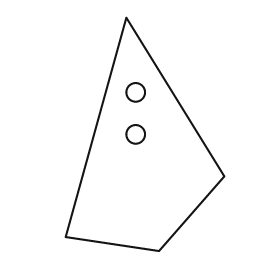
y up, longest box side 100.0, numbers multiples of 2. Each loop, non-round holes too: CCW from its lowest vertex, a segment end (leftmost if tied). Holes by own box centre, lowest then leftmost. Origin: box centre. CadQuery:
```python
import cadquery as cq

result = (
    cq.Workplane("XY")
    .moveTo(6.0, -50.0)
    .lineTo(34.0, -18.0)
    .lineTo(-8.0, 50.0)
    .lineTo(-34.0, -44.0)
    .close()
    .moveTo(-4.0, 0.0)
    .circle(4.0)
    .moveTo(-4.0, 18.0)
    .circle(4.0)
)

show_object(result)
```